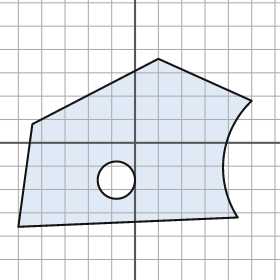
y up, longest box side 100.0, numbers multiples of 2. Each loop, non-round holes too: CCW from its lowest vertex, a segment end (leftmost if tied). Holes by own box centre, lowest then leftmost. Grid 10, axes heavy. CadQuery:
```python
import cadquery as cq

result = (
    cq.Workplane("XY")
    .moveTo(-50.0, -36.0)
    .lineTo(44.0, -32.0)
    .threePointArc((38.0, -6.0), (50.0, 18.0))
    .lineTo(10.0, 36.0)
    .lineTo(-44.0, 8.0)
    .close()
    .moveTo(-8.0, -16.0)
    .circle(8.0)
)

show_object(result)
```